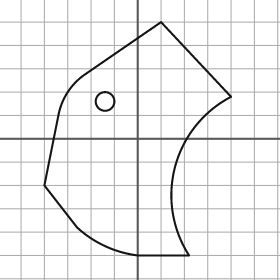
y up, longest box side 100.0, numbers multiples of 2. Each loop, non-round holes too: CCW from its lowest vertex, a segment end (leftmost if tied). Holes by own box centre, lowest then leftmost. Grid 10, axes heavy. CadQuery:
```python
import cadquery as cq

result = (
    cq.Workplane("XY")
    .moveTo(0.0, -50.0)
    .lineTo(22.0, -50.0)
    .threePointArc((16.0, -12.0), (40.0, 18.0))
    .lineTo(10.0, 50.0)
    .lineTo(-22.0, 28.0)
    .threePointArc((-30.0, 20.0), (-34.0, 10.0))
    .lineTo(-40.0, -20.0)
    .lineTo(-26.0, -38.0)
    .threePointArc((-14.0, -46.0), (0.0, -50.0))
    .close()
    .moveTo(-14.0, 16.0)
    .circle(4.0)
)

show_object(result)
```